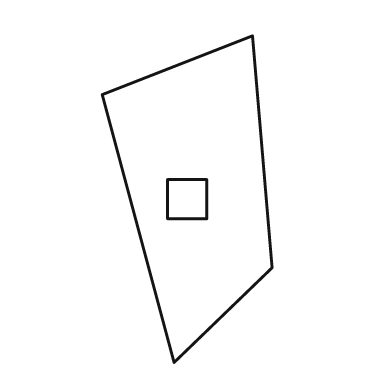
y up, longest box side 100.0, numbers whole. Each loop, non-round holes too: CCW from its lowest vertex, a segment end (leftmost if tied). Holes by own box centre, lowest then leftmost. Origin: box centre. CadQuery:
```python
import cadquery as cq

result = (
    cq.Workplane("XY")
    .moveTo(-4.0, -50.0)
    .lineTo(26.0, -21.0)
    .lineTo(20.0, 50.0)
    .lineTo(-26.0, 32.0)
    .close()
    .moveTo(-6.0, -6.0)
    .lineTo(6.0, -6.0)
    .lineTo(6.0, 6.0)
    .lineTo(-6.0, 6.0)
    .close()
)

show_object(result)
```